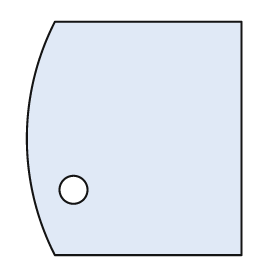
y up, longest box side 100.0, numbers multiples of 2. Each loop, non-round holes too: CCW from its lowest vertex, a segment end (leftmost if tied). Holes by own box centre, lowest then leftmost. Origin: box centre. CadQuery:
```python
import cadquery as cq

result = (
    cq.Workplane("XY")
    .moveTo(-34.0, -50.0)
    .lineTo(46.0, -50.0)
    .lineTo(46.0, 50.0)
    .lineTo(-34.0, 50.0)
    .threePointArc((-46.0, 0.0), (-34.0, -50.0))
    .close()
    .moveTo(-26.0, -22.0)
    .circle(6.0)
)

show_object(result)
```